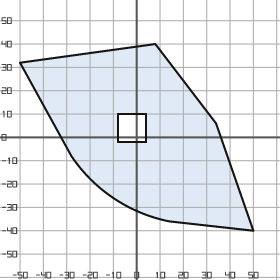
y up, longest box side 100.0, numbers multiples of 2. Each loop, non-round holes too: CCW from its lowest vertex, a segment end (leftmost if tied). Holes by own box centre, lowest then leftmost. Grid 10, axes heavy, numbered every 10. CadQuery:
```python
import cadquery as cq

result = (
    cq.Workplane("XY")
    .moveTo(50.0, -40.0)
    .lineTo(34.0, 6.0)
    .lineTo(8.0, 40.0)
    .lineTo(-50.0, 32.0)
    .lineTo(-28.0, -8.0)
    .threePointArc((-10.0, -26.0), (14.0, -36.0))
    .close()
    .moveTo(-8.0, -2.0)
    .lineTo(4.0, -2.0)
    .lineTo(4.0, 10.0)
    .lineTo(-8.0, 10.0)
    .close()
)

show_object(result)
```